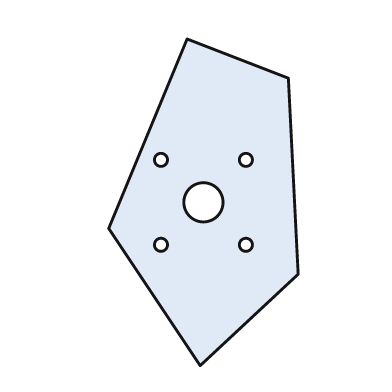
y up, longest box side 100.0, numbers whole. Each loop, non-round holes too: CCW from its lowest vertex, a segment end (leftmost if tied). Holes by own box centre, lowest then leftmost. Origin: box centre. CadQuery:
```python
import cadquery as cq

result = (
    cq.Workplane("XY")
    .moveTo(-1.0, -50.0)
    .lineTo(29.0, -22.0)
    .lineTo(26.0, 38.0)
    .lineTo(-5.0, 50.0)
    .lineTo(-29.0, -8.0)
    .close()
    .moveTo(-13.0, -13.0)
    .circle(2.0)
    .moveTo(13.0, -13.0)
    .circle(2.0)
    .moveTo(0.0, 0.0)
    .circle(6.0)
    .moveTo(-13.0, 13.0)
    .circle(2.0)
    .moveTo(13.0, 13.0)
    .circle(2.0)
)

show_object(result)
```